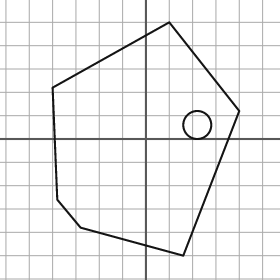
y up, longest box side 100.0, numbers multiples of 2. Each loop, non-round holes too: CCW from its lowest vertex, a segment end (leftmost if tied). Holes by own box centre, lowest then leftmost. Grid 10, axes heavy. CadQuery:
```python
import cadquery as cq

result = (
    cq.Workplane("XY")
    .moveTo(16.0, -50.0)
    .lineTo(40.0, 12.0)
    .lineTo(10.0, 50.0)
    .lineTo(-40.0, 22.0)
    .lineTo(-38.0, -26.0)
    .lineTo(-28.0, -38.0)
    .close()
    .moveTo(22.0, 6.0)
    .circle(6.0)
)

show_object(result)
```